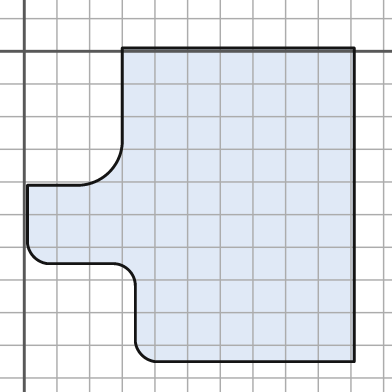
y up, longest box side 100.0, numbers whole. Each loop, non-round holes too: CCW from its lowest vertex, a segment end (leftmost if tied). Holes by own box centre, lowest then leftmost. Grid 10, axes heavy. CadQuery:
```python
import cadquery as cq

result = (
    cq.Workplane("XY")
    .moveTo(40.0, -95.0)
    .lineTo(101.0, -95.0)
    .lineTo(101.0, 1.0)
    .lineTo(30.0, 1.0)
    .lineTo(30.0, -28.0)
    .threePointArc((26.0, -37.0), (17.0, -41.0))
    .lineTo(1.0, -41.0)
    .lineTo(1.0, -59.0)
    .threePointArc((3.0, -63.0), (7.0, -65.0))
    .lineTo(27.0, -65.0)
    .threePointArc((32.0, -67.0), (34.0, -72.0))
    .lineTo(34.0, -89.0)
    .threePointArc((36.0, -93.0), (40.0, -95.0))
    .close()
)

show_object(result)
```